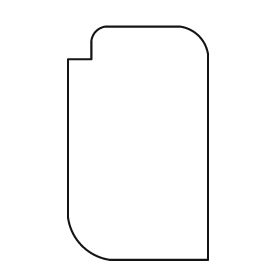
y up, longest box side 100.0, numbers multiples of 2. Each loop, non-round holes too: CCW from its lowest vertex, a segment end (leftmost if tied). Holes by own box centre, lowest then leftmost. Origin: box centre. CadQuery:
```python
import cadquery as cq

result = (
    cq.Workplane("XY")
    .moveTo(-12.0, -50.0)
    .lineTo(30.0, -50.0)
    .lineTo(30.0, 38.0)
    .threePointArc((26.0, 46.0), (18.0, 50.0))
    .lineTo(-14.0, 50.0)
    .threePointArc((-18.0, 48.0), (-20.0, 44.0))
    .lineTo(-20.0, 36.0)
    .lineTo(-30.0, 36.0)
    .lineTo(-30.0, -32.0)
    .threePointArc((-24.0, -44.0), (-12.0, -50.0))
    .close()
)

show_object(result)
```